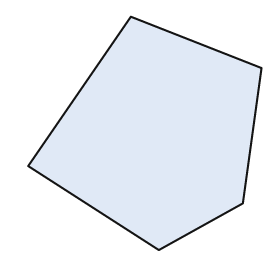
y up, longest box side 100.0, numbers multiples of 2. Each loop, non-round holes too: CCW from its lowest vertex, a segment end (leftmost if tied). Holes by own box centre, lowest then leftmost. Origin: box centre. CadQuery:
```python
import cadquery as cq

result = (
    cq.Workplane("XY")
    .moveTo(6.0, -50.0)
    .lineTo(42.0, -30.0)
    .lineTo(50.0, 28.0)
    .lineTo(-6.0, 50.0)
    .lineTo(-50.0, -14.0)
    .close()
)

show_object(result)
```